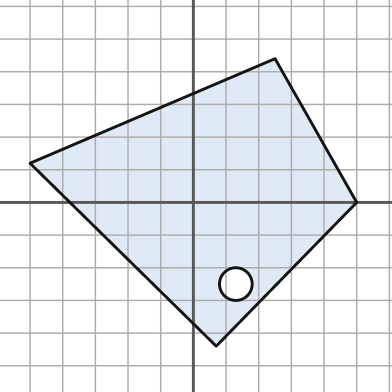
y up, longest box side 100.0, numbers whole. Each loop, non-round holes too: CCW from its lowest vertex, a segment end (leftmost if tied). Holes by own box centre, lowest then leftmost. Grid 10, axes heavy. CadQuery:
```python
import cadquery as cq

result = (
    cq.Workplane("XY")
    .moveTo(7.0, -44.0)
    .lineTo(50.0, 0.0)
    .lineTo(25.0, 44.0)
    .lineTo(-50.0, 12.0)
    .close()
    .moveTo(13.0, -25.0)
    .circle(5.0)
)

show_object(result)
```